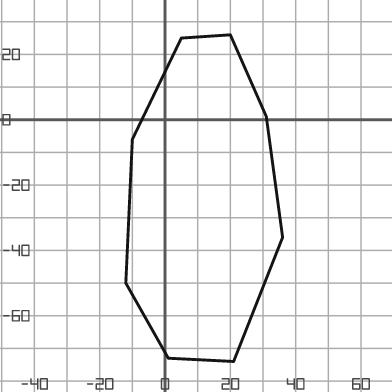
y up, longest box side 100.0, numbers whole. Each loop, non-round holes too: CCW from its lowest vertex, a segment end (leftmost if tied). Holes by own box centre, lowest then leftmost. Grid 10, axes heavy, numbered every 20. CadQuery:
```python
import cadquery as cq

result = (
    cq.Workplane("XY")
    .moveTo(21.0, -74.0)
    .lineTo(36.0, -36.0)
    .lineTo(31.0, 1.0)
    .lineTo(20.0, 26.0)
    .lineTo(5.0, 25.0)
    .lineTo(-10.0, -6.0)
    .lineTo(-12.0, -50.0)
    .lineTo(1.0, -73.0)
    .close()
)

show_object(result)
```